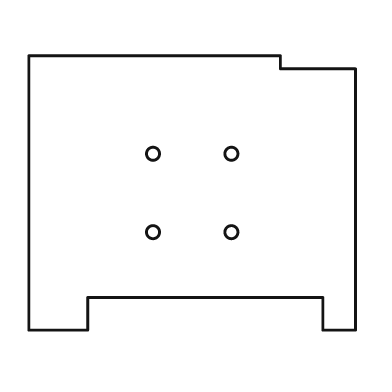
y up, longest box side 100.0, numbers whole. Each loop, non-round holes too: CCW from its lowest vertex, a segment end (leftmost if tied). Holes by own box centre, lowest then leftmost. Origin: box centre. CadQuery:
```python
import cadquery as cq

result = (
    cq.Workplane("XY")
    .moveTo(-50.0, -42.0)
    .lineTo(-32.0, -42.0)
    .lineTo(-32.0, -32.0)
    .lineTo(40.0, -32.0)
    .lineTo(40.0, -42.0)
    .lineTo(50.0, -42.0)
    .lineTo(50.0, 38.0)
    .lineTo(27.0, 38.0)
    .lineTo(27.0, 42.0)
    .lineTo(-50.0, 42.0)
    .close()
    .moveTo(-12.0, -12.0)
    .circle(2.0)
    .moveTo(12.0, -12.0)
    .circle(2.0)
    .moveTo(-12.0, 12.0)
    .circle(2.0)
    .moveTo(12.0, 12.0)
    .circle(2.0)
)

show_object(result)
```